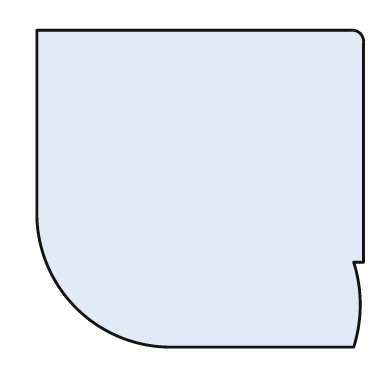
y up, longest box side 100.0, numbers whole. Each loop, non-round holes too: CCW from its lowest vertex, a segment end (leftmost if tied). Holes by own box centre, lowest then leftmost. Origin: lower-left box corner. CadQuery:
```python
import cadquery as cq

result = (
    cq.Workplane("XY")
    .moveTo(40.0, 0.0)
    .lineTo(97.0, 0.0)
    .threePointArc((99.0, 13.0), (97.0, 26.0))
    .lineTo(100.0, 26.0)
    .lineTo(100.0, 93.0)
    .threePointArc((99.0, 96.0), (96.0, 97.0))
    .lineTo(0.0, 97.0)
    .lineTo(0.0, 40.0)
    .threePointArc((12.0, 12.0), (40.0, 0.0))
    .close()
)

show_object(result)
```